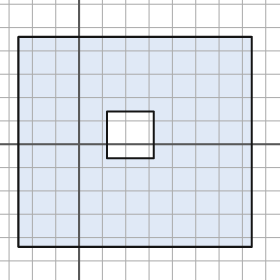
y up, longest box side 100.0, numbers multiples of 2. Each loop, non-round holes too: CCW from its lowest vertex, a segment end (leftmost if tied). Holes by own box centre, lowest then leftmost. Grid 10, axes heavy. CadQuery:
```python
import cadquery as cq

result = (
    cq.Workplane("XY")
    .moveTo(-26.0, -44.0)
    .lineTo(74.0, -44.0)
    .lineTo(74.0, 46.0)
    .lineTo(-26.0, 46.0)
    .close()
    .moveTo(12.0, -6.0)
    .lineTo(32.0, -6.0)
    .lineTo(32.0, 14.0)
    .lineTo(12.0, 14.0)
    .close()
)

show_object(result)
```